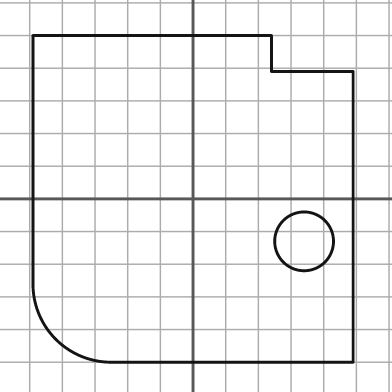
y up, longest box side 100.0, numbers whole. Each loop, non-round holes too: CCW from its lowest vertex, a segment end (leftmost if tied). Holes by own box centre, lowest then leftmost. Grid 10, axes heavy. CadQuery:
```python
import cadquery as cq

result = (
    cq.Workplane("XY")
    .moveTo(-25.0, -50.0)
    .lineTo(49.0, -50.0)
    .lineTo(49.0, 39.0)
    .lineTo(24.0, 39.0)
    .lineTo(24.0, 50.0)
    .lineTo(-49.0, 50.0)
    .lineTo(-49.0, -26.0)
    .threePointArc((-42.0, -43.0), (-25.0, -50.0))
    .close()
    .moveTo(34.0, -13.0)
    .circle(9.0)
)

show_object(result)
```